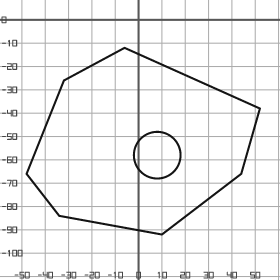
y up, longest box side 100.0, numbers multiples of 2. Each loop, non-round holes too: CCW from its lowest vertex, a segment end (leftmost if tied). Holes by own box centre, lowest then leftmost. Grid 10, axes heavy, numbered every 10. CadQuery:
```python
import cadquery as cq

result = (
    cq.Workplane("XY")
    .moveTo(10.0, -92.0)
    .lineTo(44.0, -66.0)
    .lineTo(52.0, -38.0)
    .lineTo(-6.0, -12.0)
    .lineTo(-32.0, -26.0)
    .lineTo(-48.0, -66.0)
    .lineTo(-34.0, -84.0)
    .close()
    .moveTo(8.0, -58.0)
    .circle(10.0)
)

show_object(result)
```